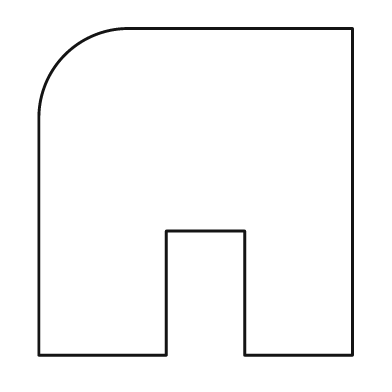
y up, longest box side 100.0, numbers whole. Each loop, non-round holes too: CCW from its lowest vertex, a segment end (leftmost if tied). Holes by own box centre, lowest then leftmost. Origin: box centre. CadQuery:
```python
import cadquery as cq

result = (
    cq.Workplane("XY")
    .moveTo(-48.0, -50.0)
    .lineTo(-9.0, -50.0)
    .lineTo(-9.0, -12.0)
    .lineTo(15.0, -12.0)
    .lineTo(15.0, -50.0)
    .lineTo(48.0, -50.0)
    .lineTo(48.0, 50.0)
    .lineTo(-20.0, 50.0)
    .threePointArc((-40.0, 42.0), (-48.0, 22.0))
    .close()
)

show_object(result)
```